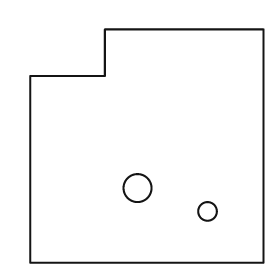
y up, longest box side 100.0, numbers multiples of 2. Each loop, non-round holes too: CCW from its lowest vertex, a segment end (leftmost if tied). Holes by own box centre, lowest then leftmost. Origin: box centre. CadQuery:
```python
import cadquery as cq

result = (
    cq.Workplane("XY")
    .moveTo(-50.0, -50.0)
    .lineTo(50.0, -50.0)
    .lineTo(50.0, 50.0)
    .lineTo(-18.0, 50.0)
    .lineTo(-18.0, 30.0)
    .lineTo(-50.0, 30.0)
    .close()
    .moveTo(26.0, -28.0)
    .circle(4.0)
    .moveTo(-4.0, -18.0)
    .circle(6.0)
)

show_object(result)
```